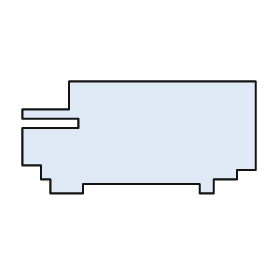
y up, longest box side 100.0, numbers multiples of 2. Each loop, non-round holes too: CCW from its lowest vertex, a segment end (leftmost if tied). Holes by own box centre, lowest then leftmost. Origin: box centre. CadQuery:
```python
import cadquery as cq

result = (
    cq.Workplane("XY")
    .moveTo(-38.0, -24.0)
    .lineTo(-24.0, -24.0)
    .lineTo(-24.0, -20.0)
    .lineTo(26.0, -20.0)
    .lineTo(26.0, -24.0)
    .lineTo(32.0, -24.0)
    .lineTo(32.0, -18.0)
    .lineTo(42.0, -18.0)
    .lineTo(42.0, -14.0)
    .lineTo(50.0, -14.0)
    .lineTo(50.0, 24.0)
    .lineTo(-30.0, 24.0)
    .lineTo(-30.0, 12.0)
    .lineTo(-50.0, 12.0)
    .lineTo(-50.0, 8.0)
    .lineTo(-26.0, 8.0)
    .lineTo(-26.0, 4.0)
    .lineTo(-50.0, 4.0)
    .lineTo(-50.0, -12.0)
    .lineTo(-42.0, -12.0)
    .lineTo(-42.0, -18.0)
    .lineTo(-38.0, -18.0)
    .close()
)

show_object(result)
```